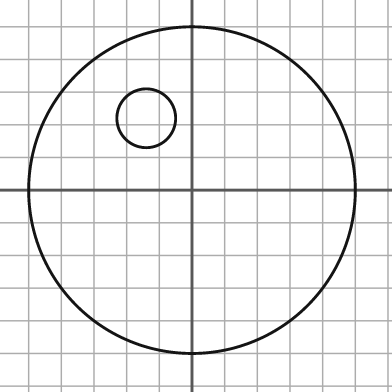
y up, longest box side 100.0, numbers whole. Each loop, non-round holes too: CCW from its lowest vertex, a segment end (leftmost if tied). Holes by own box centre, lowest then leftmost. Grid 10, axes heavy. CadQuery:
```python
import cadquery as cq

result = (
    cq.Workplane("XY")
    .moveTo(0.0, 0.0)
    .circle(50.0)
    .moveTo(-14.0, 22.0)
    .circle(9.0)
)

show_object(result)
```